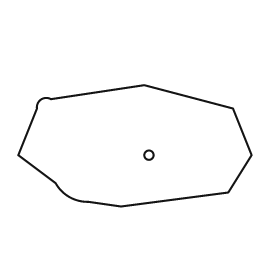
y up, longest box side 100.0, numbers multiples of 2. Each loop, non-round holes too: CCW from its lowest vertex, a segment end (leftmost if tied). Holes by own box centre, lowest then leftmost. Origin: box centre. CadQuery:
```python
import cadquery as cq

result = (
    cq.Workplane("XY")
    .moveTo(-6.0, -26.0)
    .lineTo(40.0, -20.0)
    .lineTo(50.0, -4.0)
    .lineTo(42.0, 16.0)
    .lineTo(4.0, 26.0)
    .lineTo(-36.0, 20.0)
    .threePointArc((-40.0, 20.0), (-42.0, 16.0))
    .lineTo(-50.0, -4.0)
    .lineTo(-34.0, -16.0)
    .threePointArc((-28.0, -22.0), (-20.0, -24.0))
    .close()
    .moveTo(6.0, -4.0)
    .circle(2.0)
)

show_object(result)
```